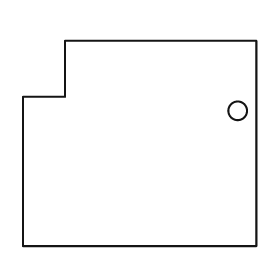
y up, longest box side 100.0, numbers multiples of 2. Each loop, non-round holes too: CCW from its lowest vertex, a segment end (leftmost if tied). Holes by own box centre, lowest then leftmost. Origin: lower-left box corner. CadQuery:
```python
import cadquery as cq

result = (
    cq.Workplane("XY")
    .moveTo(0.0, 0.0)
    .lineTo(100.0, 0.0)
    .lineTo(100.0, 88.0)
    .lineTo(18.0, 88.0)
    .lineTo(18.0, 64.0)
    .lineTo(0.0, 64.0)
    .close()
    .moveTo(92.0, 58.0)
    .circle(4.0)
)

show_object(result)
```